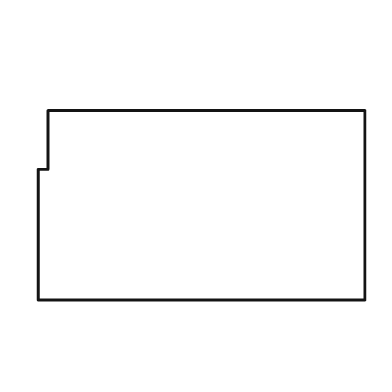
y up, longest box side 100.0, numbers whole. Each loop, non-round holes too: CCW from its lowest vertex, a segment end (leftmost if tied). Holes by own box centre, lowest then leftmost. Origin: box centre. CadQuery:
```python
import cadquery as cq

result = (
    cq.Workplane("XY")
    .moveTo(-50.0, -29.0)
    .lineTo(50.0, -29.0)
    .lineTo(50.0, 29.0)
    .lineTo(-47.0, 29.0)
    .lineTo(-47.0, 11.0)
    .lineTo(-50.0, 11.0)
    .close()
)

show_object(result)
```